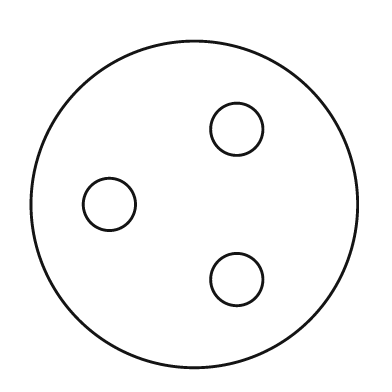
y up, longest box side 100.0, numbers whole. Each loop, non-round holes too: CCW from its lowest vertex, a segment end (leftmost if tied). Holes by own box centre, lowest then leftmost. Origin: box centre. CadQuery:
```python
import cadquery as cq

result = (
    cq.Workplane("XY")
    .moveTo(0.0, 0.0)
    .circle(50.0)
    .moveTo(13.0, -23.0)
    .circle(8.0)
    .moveTo(-26.0, 0.0)
    .circle(8.0)
    .moveTo(13.0, 23.0)
    .circle(8.0)
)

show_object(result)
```